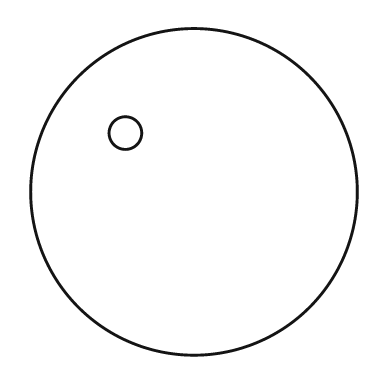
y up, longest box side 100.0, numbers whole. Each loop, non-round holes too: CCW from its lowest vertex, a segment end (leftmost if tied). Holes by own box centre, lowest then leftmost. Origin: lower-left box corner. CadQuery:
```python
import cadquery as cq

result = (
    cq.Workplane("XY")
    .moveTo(50.0, 50.0)
    .circle(50.0)
    .moveTo(29.0, 68.0)
    .circle(5.0)
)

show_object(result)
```